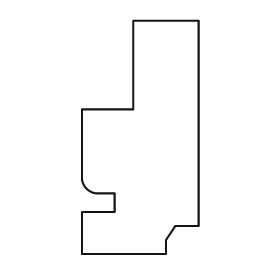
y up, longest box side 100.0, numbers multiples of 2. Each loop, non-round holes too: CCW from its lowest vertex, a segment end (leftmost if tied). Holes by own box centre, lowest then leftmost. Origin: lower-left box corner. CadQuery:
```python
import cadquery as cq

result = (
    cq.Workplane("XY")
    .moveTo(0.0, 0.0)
    .lineTo(36.0, 0.0)
    .lineTo(36.0, 6.0)
    .lineTo(40.0, 12.0)
    .lineTo(50.0, 12.0)
    .lineTo(50.0, 100.0)
    .lineTo(22.0, 100.0)
    .lineTo(22.0, 62.0)
    .lineTo(0.0, 62.0)
    .lineTo(0.0, 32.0)
    .threePointArc((2.0, 28.0), (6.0, 26.0))
    .lineTo(14.0, 26.0)
    .lineTo(14.0, 18.0)
    .lineTo(0.0, 18.0)
    .close()
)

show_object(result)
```